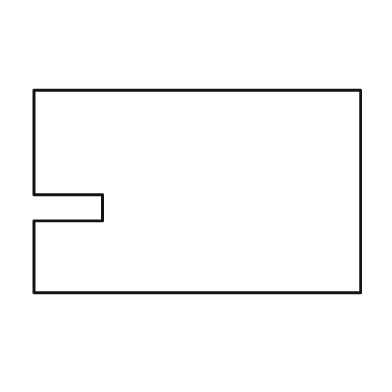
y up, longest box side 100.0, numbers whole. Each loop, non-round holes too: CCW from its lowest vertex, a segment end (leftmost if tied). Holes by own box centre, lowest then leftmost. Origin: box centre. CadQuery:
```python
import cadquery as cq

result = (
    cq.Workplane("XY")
    .moveTo(-50.0, -31.0)
    .lineTo(50.0, -31.0)
    .lineTo(50.0, 31.0)
    .lineTo(-50.0, 31.0)
    .lineTo(-50.0, -1.0)
    .lineTo(-29.0, -1.0)
    .lineTo(-29.0, -9.0)
    .lineTo(-50.0, -9.0)
    .close()
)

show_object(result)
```